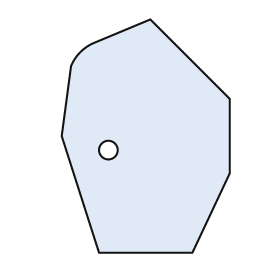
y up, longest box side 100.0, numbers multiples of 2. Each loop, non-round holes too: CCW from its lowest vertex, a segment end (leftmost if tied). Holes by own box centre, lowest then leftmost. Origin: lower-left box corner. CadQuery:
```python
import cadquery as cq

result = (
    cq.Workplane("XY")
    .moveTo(16.0, 0.0)
    .lineTo(56.0, 0.0)
    .lineTo(72.0, 34.0)
    .lineTo(72.0, 66.0)
    .lineTo(38.0, 100.0)
    .lineTo(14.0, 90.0)
    .threePointArc((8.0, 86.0), (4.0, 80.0))
    .lineTo(0.0, 50.0)
    .close()
    .moveTo(20.0, 44.0)
    .circle(4.0)
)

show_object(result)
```